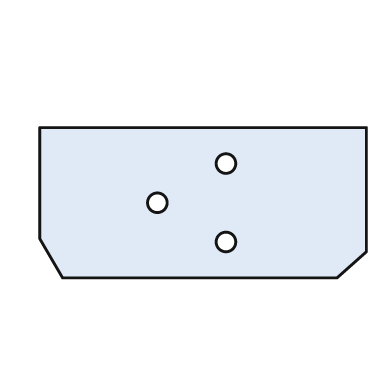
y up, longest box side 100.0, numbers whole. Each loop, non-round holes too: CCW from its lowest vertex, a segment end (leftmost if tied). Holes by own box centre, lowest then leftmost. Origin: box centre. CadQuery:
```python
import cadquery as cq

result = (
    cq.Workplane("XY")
    .moveTo(-43.0, -23.0)
    .lineTo(41.0, -23.0)
    .lineTo(50.0, -15.0)
    .lineTo(50.0, 23.0)
    .lineTo(-50.0, 23.0)
    .lineTo(-50.0, -11.0)
    .close()
    .moveTo(7.0, -12.0)
    .circle(3.0)
    .moveTo(-14.0, 0.0)
    .circle(3.0)
    .moveTo(7.0, 12.0)
    .circle(3.0)
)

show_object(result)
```